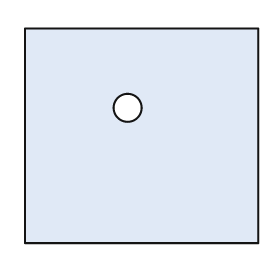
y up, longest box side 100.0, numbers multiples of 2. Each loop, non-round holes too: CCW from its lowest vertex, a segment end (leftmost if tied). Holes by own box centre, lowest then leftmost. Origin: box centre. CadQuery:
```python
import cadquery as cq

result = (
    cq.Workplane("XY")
    .moveTo(-50.0, -46.0)
    .lineTo(50.0, -46.0)
    .lineTo(50.0, 46.0)
    .lineTo(-50.0, 46.0)
    .close()
    .moveTo(-6.0, 12.0)
    .circle(6.0)
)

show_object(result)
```